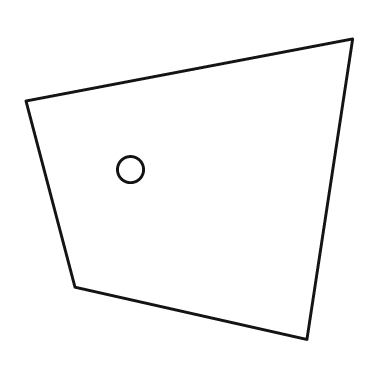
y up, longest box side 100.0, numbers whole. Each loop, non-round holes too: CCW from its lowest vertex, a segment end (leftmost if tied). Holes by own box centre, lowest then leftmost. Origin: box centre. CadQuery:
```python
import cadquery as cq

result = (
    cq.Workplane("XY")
    .moveTo(36.0, -46.0)
    .lineTo(50.0, 46.0)
    .lineTo(-50.0, 27.0)
    .lineTo(-35.0, -30.0)
    .close()
    .moveTo(-18.0, 6.0)
    .circle(4.0)
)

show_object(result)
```